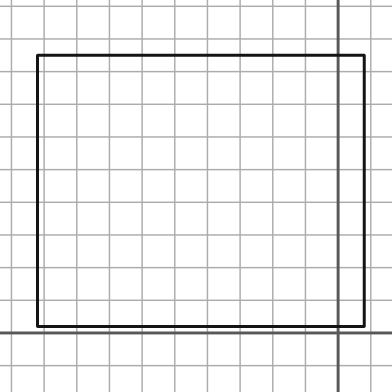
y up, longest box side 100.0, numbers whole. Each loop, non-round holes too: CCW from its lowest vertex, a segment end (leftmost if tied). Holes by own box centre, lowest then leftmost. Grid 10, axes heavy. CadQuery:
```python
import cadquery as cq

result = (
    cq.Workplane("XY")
    .moveTo(-92.0, 2.0)
    .lineTo(8.0, 2.0)
    .lineTo(8.0, 85.0)
    .lineTo(-92.0, 85.0)
    .close()
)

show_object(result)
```